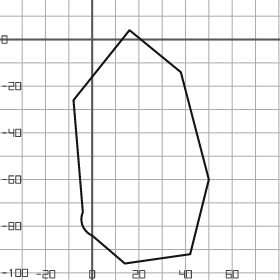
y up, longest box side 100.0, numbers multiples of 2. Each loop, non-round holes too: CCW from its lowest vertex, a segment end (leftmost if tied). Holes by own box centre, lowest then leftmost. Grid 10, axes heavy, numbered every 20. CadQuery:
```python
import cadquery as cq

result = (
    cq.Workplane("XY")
    .moveTo(14.0, -96.0)
    .lineTo(42.0, -92.0)
    .lineTo(50.0, -60.0)
    .lineTo(38.0, -14.0)
    .lineTo(16.0, 4.0)
    .lineTo(-8.0, -26.0)
    .lineTo(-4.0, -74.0)
    .threePointArc((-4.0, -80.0), (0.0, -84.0))
    .close()
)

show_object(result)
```